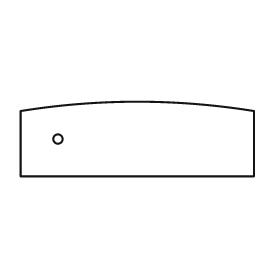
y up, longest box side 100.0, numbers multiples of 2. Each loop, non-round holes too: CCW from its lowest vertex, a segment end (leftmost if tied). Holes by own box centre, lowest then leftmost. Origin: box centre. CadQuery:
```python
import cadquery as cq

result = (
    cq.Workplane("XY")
    .moveTo(-50.0, -16.0)
    .lineTo(50.0, -16.0)
    .lineTo(50.0, 12.0)
    .threePointArc((0.0, 16.0), (-50.0, 12.0))
    .close()
    .moveTo(-34.0, 0.0)
    .circle(2.0)
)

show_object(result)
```